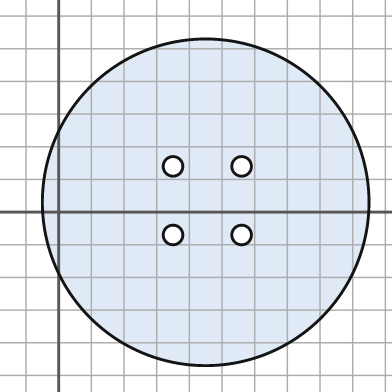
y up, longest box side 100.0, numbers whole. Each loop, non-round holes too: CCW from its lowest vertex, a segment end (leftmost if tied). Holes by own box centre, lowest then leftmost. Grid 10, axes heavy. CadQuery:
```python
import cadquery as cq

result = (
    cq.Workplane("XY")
    .moveTo(45.0, 3.0)
    .circle(50.0)
    .moveTo(35.0, -7.0)
    .circle(3.0)
    .moveTo(56.0, -7.0)
    .circle(3.0)
    .moveTo(35.0, 14.0)
    .circle(3.0)
    .moveTo(56.0, 14.0)
    .circle(3.0)
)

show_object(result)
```